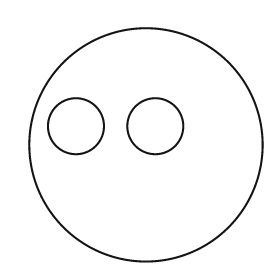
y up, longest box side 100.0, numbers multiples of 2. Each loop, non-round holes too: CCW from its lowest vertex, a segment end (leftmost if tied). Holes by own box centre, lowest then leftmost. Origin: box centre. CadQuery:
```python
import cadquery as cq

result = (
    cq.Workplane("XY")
    .moveTo(0.0, 0.0)
    .circle(50.0)
    .moveTo(-30.0, 8.0)
    .circle(12.0)
    .moveTo(4.0, 8.0)
    .circle(12.0)
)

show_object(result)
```